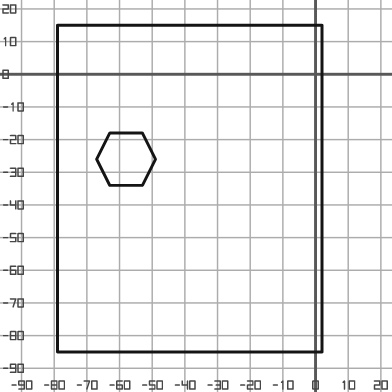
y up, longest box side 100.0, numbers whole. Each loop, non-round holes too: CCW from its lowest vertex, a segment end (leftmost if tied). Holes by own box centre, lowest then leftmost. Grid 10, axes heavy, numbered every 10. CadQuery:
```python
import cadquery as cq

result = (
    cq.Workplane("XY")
    .moveTo(-79.0, -85.0)
    .lineTo(2.0, -85.0)
    .lineTo(2.0, 15.0)
    .lineTo(-79.0, 15.0)
    .close()
    .moveTo(-63.0, -34.0)
    .lineTo(-53.0, -34.0)
    .lineTo(-49.0, -26.0)
    .lineTo(-53.0, -18.0)
    .lineTo(-63.0, -18.0)
    .lineTo(-67.0, -26.0)
    .close()
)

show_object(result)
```